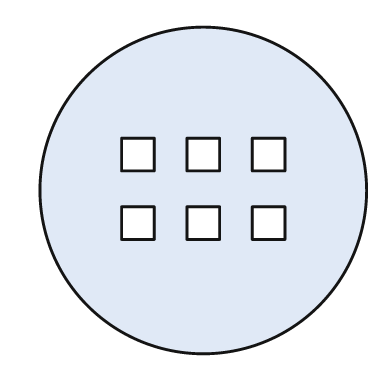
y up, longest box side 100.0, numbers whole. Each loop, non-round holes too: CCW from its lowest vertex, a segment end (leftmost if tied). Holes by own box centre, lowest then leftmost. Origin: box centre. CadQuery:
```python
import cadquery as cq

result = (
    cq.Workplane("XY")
    .moveTo(0.0, 0.0)
    .circle(50.0)
    .moveTo(-25.0, -15.0)
    .lineTo(-15.0, -15.0)
    .lineTo(-15.0, -5.0)
    .lineTo(-25.0, -5.0)
    .close()
    .moveTo(-5.0, -15.0)
    .lineTo(5.0, -15.0)
    .lineTo(5.0, -5.0)
    .lineTo(-5.0, -5.0)
    .close()
    .moveTo(15.0, -15.0)
    .lineTo(25.0, -15.0)
    .lineTo(25.0, -5.0)
    .lineTo(15.0, -5.0)
    .close()
    .moveTo(-25.0, 6.0)
    .lineTo(-15.0, 6.0)
    .lineTo(-15.0, 16.0)
    .lineTo(-25.0, 16.0)
    .close()
    .moveTo(-5.0, 6.0)
    .lineTo(5.0, 6.0)
    .lineTo(5.0, 16.0)
    .lineTo(-5.0, 16.0)
    .close()
    .moveTo(15.0, 6.0)
    .lineTo(25.0, 6.0)
    .lineTo(25.0, 16.0)
    .lineTo(15.0, 16.0)
    .close()
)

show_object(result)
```